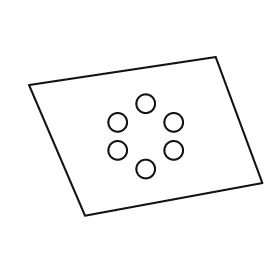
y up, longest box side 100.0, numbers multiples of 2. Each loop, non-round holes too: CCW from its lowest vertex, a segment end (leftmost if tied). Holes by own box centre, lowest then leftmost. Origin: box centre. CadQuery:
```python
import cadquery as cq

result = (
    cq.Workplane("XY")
    .moveTo(-26.0, -34.0)
    .lineTo(50.0, -20.0)
    .lineTo(30.0, 34.0)
    .lineTo(-50.0, 22.0)
    .close()
    .moveTo(0.0, -14.0)
    .circle(4.0)
    .moveTo(-12.0, -6.0)
    .circle(4.0)
    .moveTo(12.0, -6.0)
    .circle(4.0)
    .moveTo(-12.0, 6.0)
    .circle(4.0)
    .moveTo(12.0, 6.0)
    .circle(4.0)
    .moveTo(0.0, 14.0)
    .circle(4.0)
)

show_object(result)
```